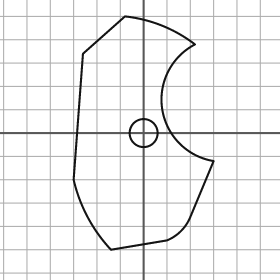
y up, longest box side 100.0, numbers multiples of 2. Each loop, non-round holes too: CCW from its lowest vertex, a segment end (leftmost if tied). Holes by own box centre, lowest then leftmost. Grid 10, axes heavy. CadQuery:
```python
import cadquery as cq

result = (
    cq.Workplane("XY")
    .moveTo(-14.0, -50.0)
    .lineTo(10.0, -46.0)
    .threePointArc((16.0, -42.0), (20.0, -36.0))
    .lineTo(30.0, -12.0)
    .threePointArc((8.0, 10.0), (22.0, 38.0))
    .threePointArc((8.0, 46.0), (-8.0, 50.0))
    .lineTo(-26.0, 34.0)
    .lineTo(-30.0, -20.0)
    .threePointArc((-24.0, -36.0), (-14.0, -50.0))
    .close()
    .moveTo(0.0, 0.0)
    .circle(6.0)
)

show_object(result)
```